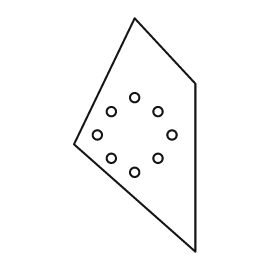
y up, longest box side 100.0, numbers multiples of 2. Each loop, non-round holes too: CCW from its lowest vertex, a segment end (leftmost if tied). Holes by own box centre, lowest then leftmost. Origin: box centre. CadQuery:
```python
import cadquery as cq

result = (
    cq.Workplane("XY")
    .moveTo(26.0, -50.0)
    .lineTo(26.0, 22.0)
    .lineTo(0.0, 50.0)
    .lineTo(-26.0, -4.0)
    .close()
    .moveTo(0.0, -16.0)
    .circle(2.0)
    .moveTo(-10.0, -10.0)
    .circle(2.0)
    .moveTo(10.0, -10.0)
    .circle(2.0)
    .moveTo(-16.0, 0.0)
    .circle(2.0)
    .moveTo(16.0, 0.0)
    .circle(2.0)
    .moveTo(-10.0, 10.0)
    .circle(2.0)
    .moveTo(10.0, 10.0)
    .circle(2.0)
    .moveTo(0.0, 16.0)
    .circle(2.0)
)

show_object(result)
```